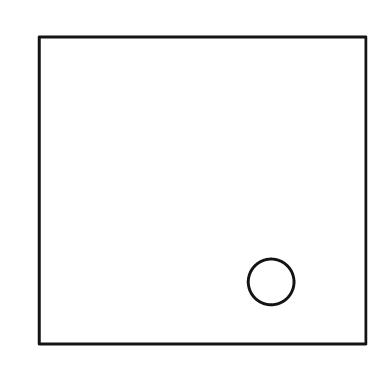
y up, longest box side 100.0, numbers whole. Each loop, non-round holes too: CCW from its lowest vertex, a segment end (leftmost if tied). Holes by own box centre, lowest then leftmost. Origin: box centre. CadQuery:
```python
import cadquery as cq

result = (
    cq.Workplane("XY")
    .moveTo(-50.0, -47.0)
    .lineTo(50.0, -47.0)
    .lineTo(50.0, 47.0)
    .lineTo(-50.0, 47.0)
    .close()
    .moveTo(21.0, -28.0)
    .circle(7.0)
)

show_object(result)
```